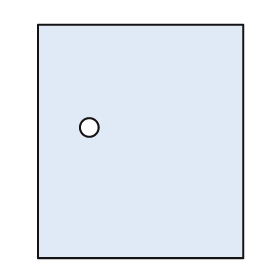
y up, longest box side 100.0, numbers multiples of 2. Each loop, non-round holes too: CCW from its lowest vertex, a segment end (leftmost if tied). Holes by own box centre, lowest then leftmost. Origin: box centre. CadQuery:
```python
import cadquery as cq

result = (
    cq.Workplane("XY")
    .moveTo(-44.0, -50.0)
    .lineTo(44.0, -50.0)
    .lineTo(44.0, 50.0)
    .lineTo(-44.0, 50.0)
    .close()
    .moveTo(-22.0, 6.0)
    .circle(4.0)
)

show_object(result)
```